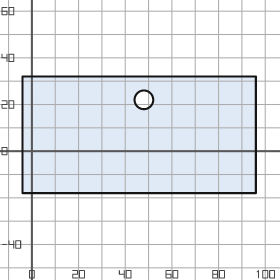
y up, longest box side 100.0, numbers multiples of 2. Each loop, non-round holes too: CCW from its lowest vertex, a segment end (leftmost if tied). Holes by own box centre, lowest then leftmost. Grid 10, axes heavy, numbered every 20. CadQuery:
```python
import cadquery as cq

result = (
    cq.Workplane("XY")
    .moveTo(-4.0, -18.0)
    .lineTo(96.0, -18.0)
    .lineTo(96.0, 32.0)
    .lineTo(-4.0, 32.0)
    .close()
    .moveTo(48.0, 22.0)
    .circle(4.0)
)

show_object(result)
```